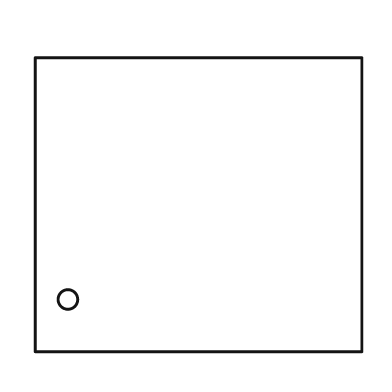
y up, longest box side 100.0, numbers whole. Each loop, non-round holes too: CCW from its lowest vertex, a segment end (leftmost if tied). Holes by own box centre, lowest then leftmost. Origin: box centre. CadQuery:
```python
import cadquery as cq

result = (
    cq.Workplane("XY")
    .moveTo(-50.0, -45.0)
    .lineTo(50.0, -45.0)
    .lineTo(50.0, 45.0)
    .lineTo(-50.0, 45.0)
    .close()
    .moveTo(-40.0, -29.0)
    .circle(3.0)
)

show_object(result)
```